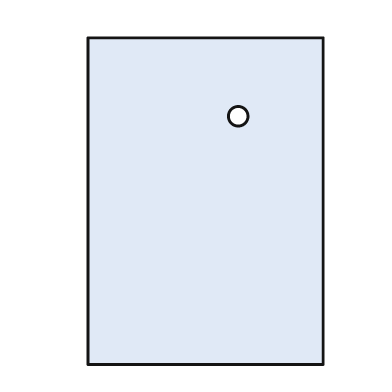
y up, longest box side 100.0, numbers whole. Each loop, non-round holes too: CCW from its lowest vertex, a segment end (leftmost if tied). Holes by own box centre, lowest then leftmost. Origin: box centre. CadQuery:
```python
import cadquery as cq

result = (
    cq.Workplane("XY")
    .moveTo(-36.0, -50.0)
    .lineTo(36.0, -50.0)
    .lineTo(36.0, 50.0)
    .lineTo(-36.0, 50.0)
    .close()
    .moveTo(10.0, 26.0)
    .circle(3.0)
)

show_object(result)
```